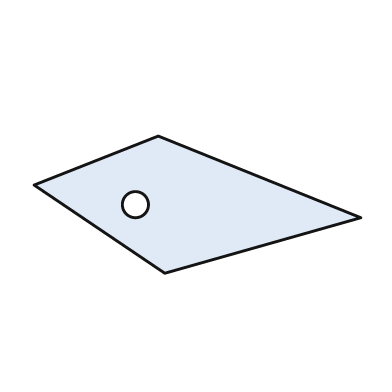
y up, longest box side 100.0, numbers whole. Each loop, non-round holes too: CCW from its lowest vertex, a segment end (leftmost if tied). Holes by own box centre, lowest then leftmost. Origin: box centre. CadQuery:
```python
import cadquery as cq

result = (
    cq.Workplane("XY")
    .moveTo(-10.0, -21.0)
    .lineTo(50.0, -4.0)
    .lineTo(-12.0, 21.0)
    .lineTo(-50.0, 6.0)
    .close()
    .moveTo(-19.0, 0.0)
    .circle(4.0)
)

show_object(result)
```